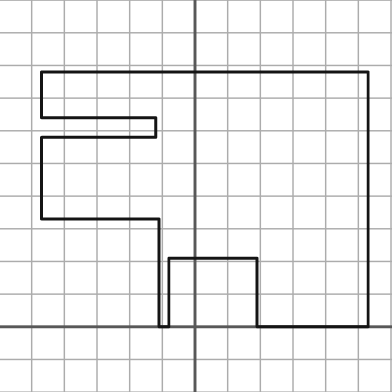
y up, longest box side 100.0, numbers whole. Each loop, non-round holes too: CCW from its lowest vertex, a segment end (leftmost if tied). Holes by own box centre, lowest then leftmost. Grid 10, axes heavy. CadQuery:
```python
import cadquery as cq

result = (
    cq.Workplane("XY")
    .moveTo(-11.0, 0.0)
    .lineTo(-8.0, 0.0)
    .lineTo(-8.0, 21.0)
    .lineTo(19.0, 21.0)
    .lineTo(19.0, 0.0)
    .lineTo(53.0, 0.0)
    .lineTo(53.0, 78.0)
    .lineTo(-47.0, 78.0)
    .lineTo(-47.0, 64.0)
    .lineTo(-12.0, 64.0)
    .lineTo(-12.0, 58.0)
    .lineTo(-47.0, 58.0)
    .lineTo(-47.0, 33.0)
    .lineTo(-11.0, 33.0)
    .close()
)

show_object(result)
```